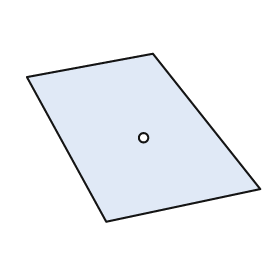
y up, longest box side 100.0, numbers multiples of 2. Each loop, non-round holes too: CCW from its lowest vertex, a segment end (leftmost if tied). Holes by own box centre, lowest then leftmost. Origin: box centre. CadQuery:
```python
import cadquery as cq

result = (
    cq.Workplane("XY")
    .moveTo(-16.0, -36.0)
    .lineTo(50.0, -22.0)
    .lineTo(4.0, 36.0)
    .lineTo(-50.0, 26.0)
    .close()
    .moveTo(0.0, 0.0)
    .circle(2.0)
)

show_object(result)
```